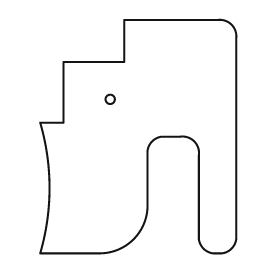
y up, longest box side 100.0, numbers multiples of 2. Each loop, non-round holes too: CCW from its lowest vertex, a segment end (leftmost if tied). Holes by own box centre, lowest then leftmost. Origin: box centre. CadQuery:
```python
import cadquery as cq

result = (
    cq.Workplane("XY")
    .moveTo(-42.0, -50.0)
    .lineTo(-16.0, -50.0)
    .threePointArc((-2.0, -44.0), (4.0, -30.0))
    .lineTo(4.0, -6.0)
    .threePointArc((6.0, -2.0), (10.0, 0.0))
    .lineTo(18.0, 0.0)
    .threePointArc((24.0, -2.0), (26.0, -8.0))
    .lineTo(26.0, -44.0)
    .threePointArc((28.0, -48.0), (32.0, -50.0))
    .lineTo(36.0, -50.0)
    .threePointArc((40.0, -48.0), (42.0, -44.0))
    .lineTo(42.0, 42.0)
    .threePointArc((40.0, 48.0), (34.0, 50.0))
    .lineTo(-6.0, 50.0)
    .lineTo(-6.0, 32.0)
    .lineTo(-32.0, 32.0)
    .lineTo(-32.0, 6.0)
    .lineTo(-42.0, 6.0)
    .threePointArc((-38.0, -22.0), (-42.0, -50.0))
    .close()
    .moveTo(-12.0, 16.0)
    .circle(2.0)
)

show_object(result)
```